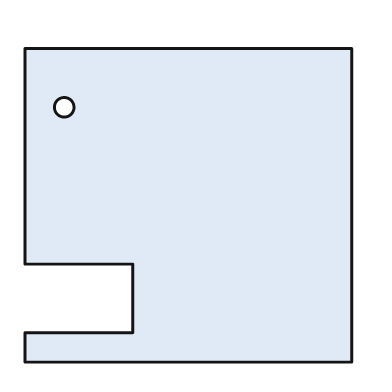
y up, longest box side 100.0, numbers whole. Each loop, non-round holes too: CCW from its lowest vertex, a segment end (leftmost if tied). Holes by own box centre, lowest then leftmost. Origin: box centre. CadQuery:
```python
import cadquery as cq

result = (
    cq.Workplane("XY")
    .moveTo(-50.0, -48.0)
    .lineTo(50.0, -48.0)
    .lineTo(50.0, 48.0)
    .lineTo(-50.0, 48.0)
    .lineTo(-50.0, -18.0)
    .lineTo(-17.0, -18.0)
    .lineTo(-17.0, -39.0)
    .lineTo(-50.0, -39.0)
    .close()
    .moveTo(-38.0, 30.0)
    .circle(3.0)
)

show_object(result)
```